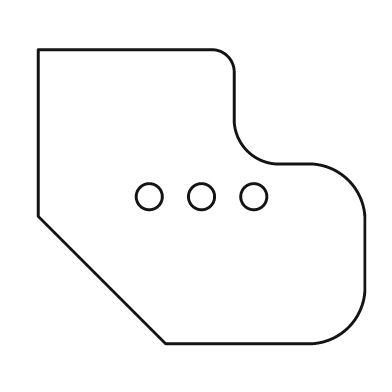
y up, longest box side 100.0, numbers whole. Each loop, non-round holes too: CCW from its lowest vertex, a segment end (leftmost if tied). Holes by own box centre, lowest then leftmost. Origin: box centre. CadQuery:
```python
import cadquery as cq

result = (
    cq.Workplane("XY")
    .moveTo(-11.0, -45.0)
    .lineTo(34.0, -45.0)
    .threePointArc((45.0, -40.0), (50.0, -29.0))
    .lineTo(50.0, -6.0)
    .threePointArc((45.0, 5.0), (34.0, 10.0))
    .lineTo(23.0, 10.0)
    .threePointArc((14.0, 14.0), (10.0, 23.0))
    .lineTo(10.0, 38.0)
    .threePointArc((8.0, 43.0), (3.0, 45.0))
    .lineTo(-50.0, 45.0)
    .lineTo(-50.0, -6.0)
    .close()
    .moveTo(-16.0, 0.0)
    .circle(4.0)
    .moveTo(0.0, 0.0)
    .circle(4.0)
    .moveTo(16.0, 0.0)
    .circle(4.0)
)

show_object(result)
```